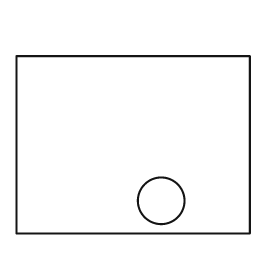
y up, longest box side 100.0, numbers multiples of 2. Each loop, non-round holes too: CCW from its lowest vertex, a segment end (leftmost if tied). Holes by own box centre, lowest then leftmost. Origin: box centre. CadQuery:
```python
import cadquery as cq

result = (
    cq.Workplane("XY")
    .moveTo(-50.0, -38.0)
    .lineTo(50.0, -38.0)
    .lineTo(50.0, 38.0)
    .lineTo(-50.0, 38.0)
    .close()
    .moveTo(12.0, -24.0)
    .circle(10.0)
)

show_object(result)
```